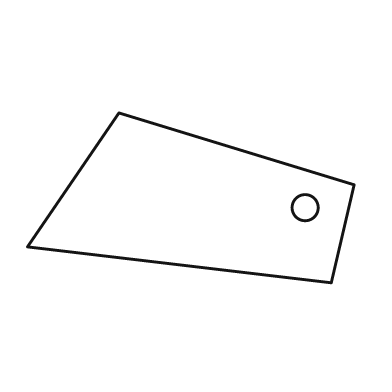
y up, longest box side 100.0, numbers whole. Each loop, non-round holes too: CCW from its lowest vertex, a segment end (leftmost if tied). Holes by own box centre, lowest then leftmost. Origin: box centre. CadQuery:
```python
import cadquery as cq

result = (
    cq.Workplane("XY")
    .moveTo(43.0, -26.0)
    .lineTo(50.0, 4.0)
    .lineTo(-22.0, 26.0)
    .lineTo(-50.0, -15.0)
    .close()
    .moveTo(35.0, -3.0)
    .circle(4.0)
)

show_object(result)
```